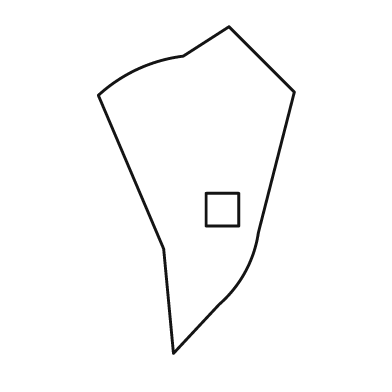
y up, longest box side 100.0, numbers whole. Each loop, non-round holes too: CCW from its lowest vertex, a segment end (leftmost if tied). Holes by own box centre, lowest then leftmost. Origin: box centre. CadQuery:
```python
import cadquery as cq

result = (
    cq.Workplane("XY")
    .moveTo(-7.0, -50.0)
    .lineTo(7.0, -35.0)
    .threePointArc((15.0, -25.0), (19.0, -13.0))
    .lineTo(30.0, 30.0)
    .lineTo(10.0, 50.0)
    .lineTo(-4.0, 41.0)
    .threePointArc((-18.0, 37.0), (-30.0, 29.0))
    .lineTo(-10.0, -18.0)
    .close()
    .moveTo(3.0, -11.0)
    .lineTo(13.0, -11.0)
    .lineTo(13.0, -1.0)
    .lineTo(3.0, -1.0)
    .close()
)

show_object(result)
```